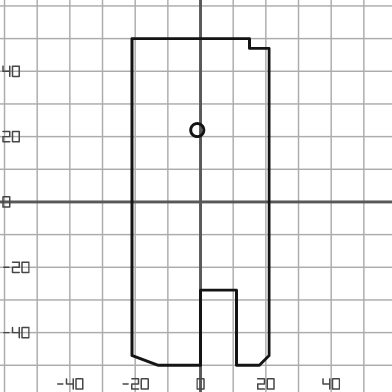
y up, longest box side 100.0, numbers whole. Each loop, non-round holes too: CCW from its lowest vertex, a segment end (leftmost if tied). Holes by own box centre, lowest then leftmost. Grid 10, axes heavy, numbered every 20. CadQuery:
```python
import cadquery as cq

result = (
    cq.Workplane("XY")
    .moveTo(-13.0, -50.0)
    .lineTo(0.0, -50.0)
    .lineTo(0.0, -27.0)
    .lineTo(11.0, -27.0)
    .lineTo(11.0, -50.0)
    .lineTo(18.0, -50.0)
    .lineTo(21.0, -47.0)
    .lineTo(21.0, 47.0)
    .lineTo(15.0, 47.0)
    .lineTo(15.0, 50.0)
    .lineTo(-21.0, 50.0)
    .lineTo(-21.0, -47.0)
    .close()
    .moveTo(-1.0, 22.0)
    .circle(2.0)
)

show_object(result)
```